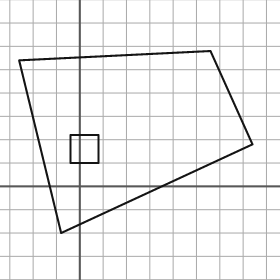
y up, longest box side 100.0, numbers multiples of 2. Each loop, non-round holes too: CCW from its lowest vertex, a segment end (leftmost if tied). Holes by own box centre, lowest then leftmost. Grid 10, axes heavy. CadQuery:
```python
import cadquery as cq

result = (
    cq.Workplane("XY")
    .moveTo(-8.0, -20.0)
    .lineTo(74.0, 18.0)
    .lineTo(56.0, 58.0)
    .lineTo(-26.0, 54.0)
    .close()
    .moveTo(-4.0, 10.0)
    .lineTo(8.0, 10.0)
    .lineTo(8.0, 22.0)
    .lineTo(-4.0, 22.0)
    .close()
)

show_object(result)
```